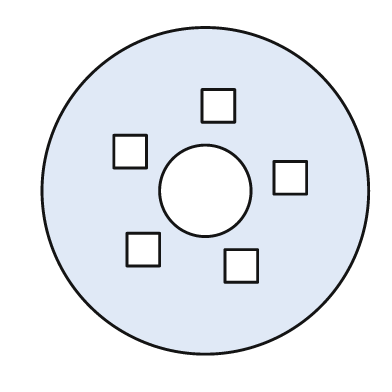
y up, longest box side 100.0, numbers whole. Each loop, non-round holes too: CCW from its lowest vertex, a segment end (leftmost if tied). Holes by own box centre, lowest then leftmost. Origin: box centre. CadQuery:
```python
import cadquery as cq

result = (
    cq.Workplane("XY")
    .moveTo(0.0, 0.0)
    .circle(50.0)
    .moveTo(6.0, -28.0)
    .lineTo(16.0, -28.0)
    .lineTo(16.0, -18.0)
    .lineTo(6.0, -18.0)
    .close()
    .moveTo(-24.0, -23.0)
    .lineTo(-14.0, -23.0)
    .lineTo(-14.0, -13.0)
    .lineTo(-24.0, -13.0)
    .close()
    .moveTo(0.0, 0.0)
    .circle(14.0)
    .moveTo(21.0, -1.0)
    .lineTo(31.0, -1.0)
    .lineTo(31.0, 9.0)
    .lineTo(21.0, 9.0)
    .close()
    .moveTo(-28.0, 7.0)
    .lineTo(-18.0, 7.0)
    .lineTo(-18.0, 17.0)
    .lineTo(-28.0, 17.0)
    .close()
    .moveTo(-1.0, 21.0)
    .lineTo(9.0, 21.0)
    .lineTo(9.0, 31.0)
    .lineTo(-1.0, 31.0)
    .close()
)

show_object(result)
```